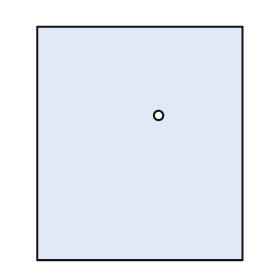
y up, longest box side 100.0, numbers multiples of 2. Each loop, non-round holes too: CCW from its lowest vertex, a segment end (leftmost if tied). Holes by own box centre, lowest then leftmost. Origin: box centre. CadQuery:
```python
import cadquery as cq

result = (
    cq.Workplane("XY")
    .moveTo(-44.0, -50.0)
    .lineTo(44.0, -50.0)
    .lineTo(44.0, 50.0)
    .lineTo(-44.0, 50.0)
    .close()
    .moveTo(8.0, 12.0)
    .circle(2.0)
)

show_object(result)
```